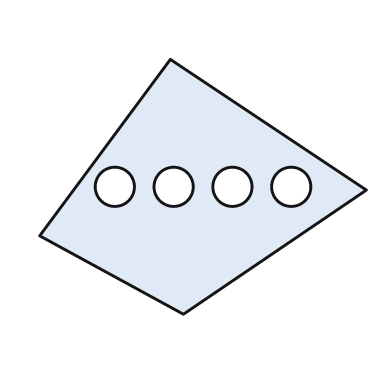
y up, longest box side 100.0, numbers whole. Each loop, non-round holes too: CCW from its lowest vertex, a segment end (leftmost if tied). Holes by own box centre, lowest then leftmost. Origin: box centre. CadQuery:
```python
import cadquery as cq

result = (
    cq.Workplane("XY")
    .moveTo(-6.0, -39.0)
    .lineTo(50.0, -1.0)
    .lineTo(-10.0, 39.0)
    .lineTo(-50.0, -15.0)
    .close()
    .moveTo(-27.0, 0.0)
    .circle(6.0)
    .moveTo(-9.0, 0.0)
    .circle(6.0)
    .moveTo(9.0, 0.0)
    .circle(6.0)
    .moveTo(27.0, 0.0)
    .circle(6.0)
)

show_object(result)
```